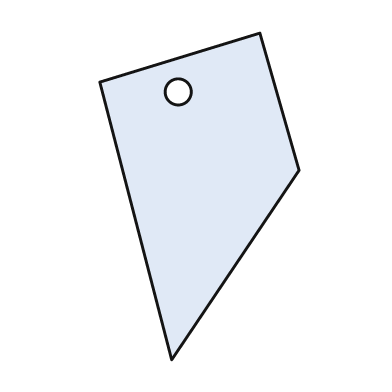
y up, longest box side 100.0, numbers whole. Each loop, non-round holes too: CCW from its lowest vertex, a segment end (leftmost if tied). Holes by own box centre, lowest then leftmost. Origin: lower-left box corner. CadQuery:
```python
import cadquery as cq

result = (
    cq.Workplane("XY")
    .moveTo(22.0, 0.0)
    .lineTo(61.0, 58.0)
    .lineTo(49.0, 100.0)
    .lineTo(0.0, 85.0)
    .close()
    .moveTo(24.0, 82.0)
    .circle(4.0)
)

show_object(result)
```